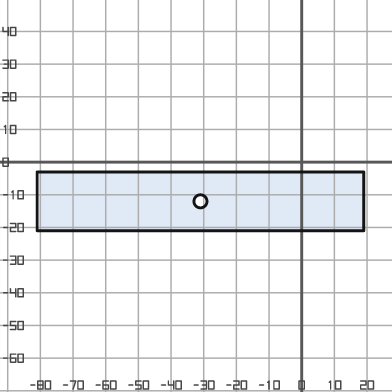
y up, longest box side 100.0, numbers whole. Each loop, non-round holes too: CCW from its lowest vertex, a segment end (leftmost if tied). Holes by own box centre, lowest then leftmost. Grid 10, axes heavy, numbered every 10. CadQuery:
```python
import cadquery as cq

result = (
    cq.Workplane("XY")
    .moveTo(-81.0, -21.0)
    .lineTo(19.0, -21.0)
    .lineTo(19.0, -3.0)
    .lineTo(-81.0, -3.0)
    .close()
    .moveTo(-31.0, -12.0)
    .circle(2.0)
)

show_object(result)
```